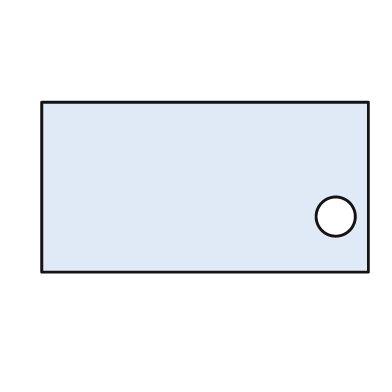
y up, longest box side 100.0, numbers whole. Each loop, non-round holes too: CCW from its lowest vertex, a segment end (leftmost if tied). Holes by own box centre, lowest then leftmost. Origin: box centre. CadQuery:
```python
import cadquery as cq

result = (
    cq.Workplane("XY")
    .moveTo(-50.0, -26.0)
    .lineTo(50.0, -26.0)
    .lineTo(50.0, 26.0)
    .lineTo(-50.0, 26.0)
    .close()
    .moveTo(40.0, -9.0)
    .circle(6.0)
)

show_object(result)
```